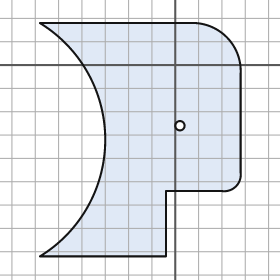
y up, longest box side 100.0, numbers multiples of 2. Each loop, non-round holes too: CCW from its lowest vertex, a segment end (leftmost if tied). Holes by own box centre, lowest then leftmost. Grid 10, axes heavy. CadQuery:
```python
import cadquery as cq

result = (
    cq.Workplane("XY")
    .moveTo(-58.0, -82.0)
    .lineTo(-4.0, -82.0)
    .lineTo(-4.0, -54.0)
    .lineTo(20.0, -54.0)
    .threePointArc((26.0, -52.0), (28.0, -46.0))
    .lineTo(28.0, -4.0)
    .threePointArc((22.0, 12.0), (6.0, 18.0))
    .lineTo(-58.0, 18.0)
    .threePointArc((-30.0, -32.0), (-58.0, -82.0))
    .close()
    .moveTo(2.0, -26.0)
    .circle(2.0)
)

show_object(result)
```